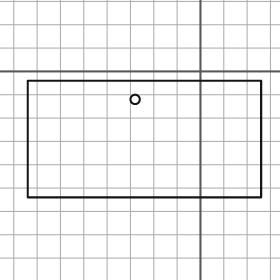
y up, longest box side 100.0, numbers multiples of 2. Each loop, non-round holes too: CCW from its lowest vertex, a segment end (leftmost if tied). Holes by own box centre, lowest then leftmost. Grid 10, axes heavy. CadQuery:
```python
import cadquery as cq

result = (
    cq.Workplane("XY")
    .moveTo(-74.0, -54.0)
    .lineTo(26.0, -54.0)
    .lineTo(26.0, -4.0)
    .lineTo(-74.0, -4.0)
    .close()
    .moveTo(-28.0, -12.0)
    .circle(2.0)
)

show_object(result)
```